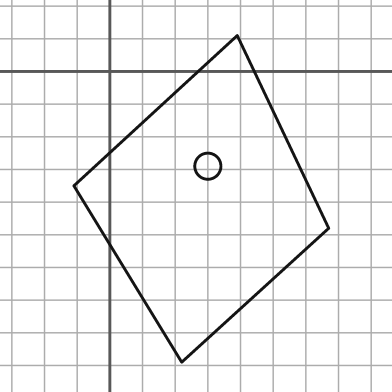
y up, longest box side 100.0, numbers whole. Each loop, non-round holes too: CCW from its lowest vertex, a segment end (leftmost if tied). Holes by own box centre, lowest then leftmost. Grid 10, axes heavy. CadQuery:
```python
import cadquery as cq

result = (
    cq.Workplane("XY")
    .moveTo(22.0, -89.0)
    .lineTo(67.0, -48.0)
    .lineTo(39.0, 11.0)
    .lineTo(-11.0, -35.0)
    .close()
    .moveTo(30.0, -29.0)
    .circle(4.0)
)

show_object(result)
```